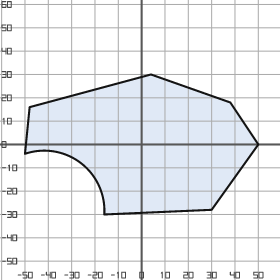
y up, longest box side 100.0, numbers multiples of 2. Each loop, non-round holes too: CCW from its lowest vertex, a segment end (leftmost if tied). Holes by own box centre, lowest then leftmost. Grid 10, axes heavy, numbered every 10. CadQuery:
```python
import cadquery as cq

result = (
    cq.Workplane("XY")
    .moveTo(-16.0, -30.0)
    .lineTo(30.0, -28.0)
    .lineTo(50.0, 0.0)
    .lineTo(38.0, 18.0)
    .lineTo(4.0, 30.0)
    .lineTo(-48.0, 16.0)
    .lineTo(-50.0, -4.0)
    .threePointArc((-26.0, -8.0), (-16.0, -30.0))
    .close()
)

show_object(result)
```